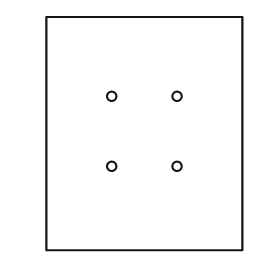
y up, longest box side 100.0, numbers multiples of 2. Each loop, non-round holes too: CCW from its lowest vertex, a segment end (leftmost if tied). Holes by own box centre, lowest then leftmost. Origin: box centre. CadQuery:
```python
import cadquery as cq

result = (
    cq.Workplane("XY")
    .moveTo(-42.0, -50.0)
    .lineTo(42.0, -50.0)
    .lineTo(42.0, 50.0)
    .lineTo(-42.0, 50.0)
    .close()
    .moveTo(-14.0, -14.0)
    .circle(2.0)
    .moveTo(14.0, -14.0)
    .circle(2.0)
    .moveTo(-14.0, 16.0)
    .circle(2.0)
    .moveTo(14.0, 16.0)
    .circle(2.0)
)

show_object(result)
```